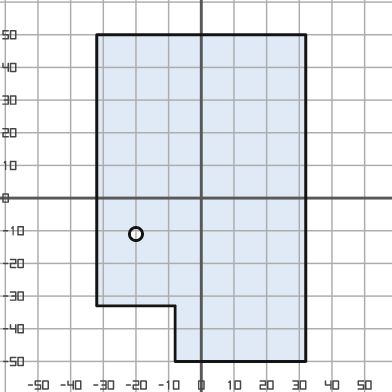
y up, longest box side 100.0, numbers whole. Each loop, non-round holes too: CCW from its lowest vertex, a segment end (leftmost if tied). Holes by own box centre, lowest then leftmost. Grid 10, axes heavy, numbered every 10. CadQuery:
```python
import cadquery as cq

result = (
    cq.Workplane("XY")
    .moveTo(-8.0, -50.0)
    .lineTo(32.0, -50.0)
    .lineTo(32.0, 50.0)
    .lineTo(-32.0, 50.0)
    .lineTo(-32.0, -33.0)
    .lineTo(-8.0, -33.0)
    .close()
    .moveTo(-20.0, -11.0)
    .circle(2.0)
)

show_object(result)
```